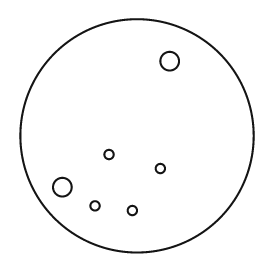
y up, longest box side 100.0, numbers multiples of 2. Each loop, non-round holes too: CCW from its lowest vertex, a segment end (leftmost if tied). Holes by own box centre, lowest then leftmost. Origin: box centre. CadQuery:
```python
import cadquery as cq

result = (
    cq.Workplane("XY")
    .moveTo(0.0, 0.0)
    .circle(50.0)
    .moveTo(-2.0, -32.0)
    .circle(2.0)
    .moveTo(-18.0, -30.0)
    .circle(2.0)
    .moveTo(-32.0, -22.0)
    .circle(4.0)
    .moveTo(10.0, -14.0)
    .circle(2.0)
    .moveTo(-12.0, -8.0)
    .circle(2.0)
    .moveTo(14.0, 32.0)
    .circle(4.0)
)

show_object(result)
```